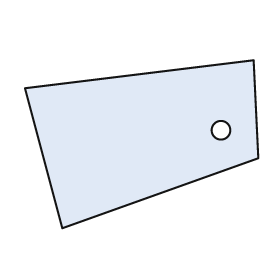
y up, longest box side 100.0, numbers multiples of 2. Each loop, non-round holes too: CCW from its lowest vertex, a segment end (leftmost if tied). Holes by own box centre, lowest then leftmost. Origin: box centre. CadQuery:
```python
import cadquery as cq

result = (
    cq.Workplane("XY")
    .moveTo(-34.0, -36.0)
    .lineTo(50.0, -6.0)
    .lineTo(48.0, 36.0)
    .lineTo(-50.0, 24.0)
    .close()
    .moveTo(34.0, 6.0)
    .circle(4.0)
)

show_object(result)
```